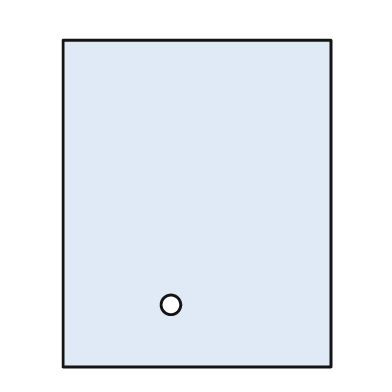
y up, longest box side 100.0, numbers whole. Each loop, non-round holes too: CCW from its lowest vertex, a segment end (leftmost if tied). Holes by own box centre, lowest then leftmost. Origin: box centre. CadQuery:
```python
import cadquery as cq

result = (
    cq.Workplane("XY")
    .moveTo(-41.0, -50.0)
    .lineTo(41.0, -50.0)
    .lineTo(41.0, 50.0)
    .lineTo(-41.0, 50.0)
    .close()
    .moveTo(-8.0, -31.0)
    .circle(3.0)
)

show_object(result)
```